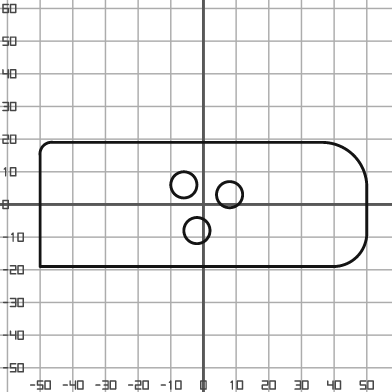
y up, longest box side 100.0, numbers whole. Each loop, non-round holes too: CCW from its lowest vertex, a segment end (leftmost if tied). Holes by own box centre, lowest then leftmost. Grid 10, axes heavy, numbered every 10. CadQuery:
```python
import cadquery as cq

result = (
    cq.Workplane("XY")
    .moveTo(-50.0, -19.0)
    .lineTo(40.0, -19.0)
    .threePointArc((47.0, -16.0), (50.0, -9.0))
    .lineTo(50.0, 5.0)
    .threePointArc((46.0, 15.0), (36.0, 19.0))
    .lineTo(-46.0, 19.0)
    .threePointArc((-49.0, 18.0), (-50.0, 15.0))
    .close()
    .moveTo(-2.0, -8.0)
    .circle(4.0)
    .moveTo(8.0, 3.0)
    .circle(4.0)
    .moveTo(-6.0, 6.0)
    .circle(4.0)
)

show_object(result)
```